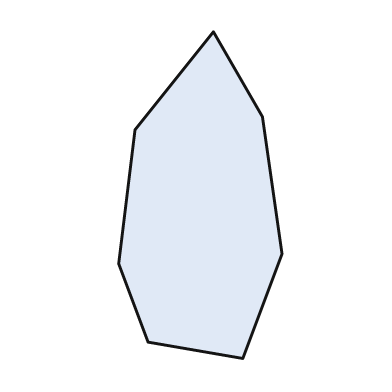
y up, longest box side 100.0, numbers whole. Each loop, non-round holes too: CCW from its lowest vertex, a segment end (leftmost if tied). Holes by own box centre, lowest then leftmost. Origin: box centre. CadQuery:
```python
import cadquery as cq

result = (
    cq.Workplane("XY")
    .moveTo(13.0, -50.0)
    .lineTo(25.0, -18.0)
    .lineTo(19.0, 24.0)
    .lineTo(4.0, 50.0)
    .lineTo(-20.0, 20.0)
    .lineTo(-25.0, -21.0)
    .lineTo(-16.0, -45.0)
    .close()
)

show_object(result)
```